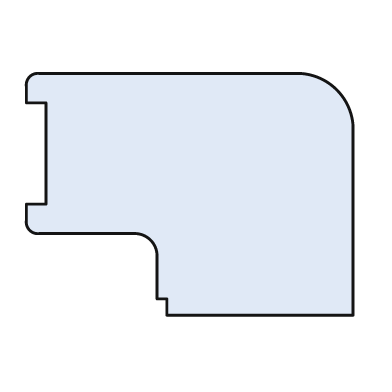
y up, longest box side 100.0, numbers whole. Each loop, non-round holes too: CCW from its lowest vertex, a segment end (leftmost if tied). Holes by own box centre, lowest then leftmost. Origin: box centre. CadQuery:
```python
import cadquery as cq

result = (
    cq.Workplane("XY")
    .moveTo(-7.0, -37.0)
    .lineTo(50.0, -37.0)
    .lineTo(50.0, 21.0)
    .threePointArc((45.0, 32.0), (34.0, 37.0))
    .lineTo(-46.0, 37.0)
    .threePointArc((-49.0, 36.0), (-50.0, 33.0))
    .lineTo(-50.0, 28.0)
    .lineTo(-44.0, 28.0)
    .lineTo(-44.0, -3.0)
    .lineTo(-50.0, -3.0)
    .lineTo(-50.0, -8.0)
    .threePointArc((-49.0, -11.0), (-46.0, -12.0))
    .lineTo(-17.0, -12.0)
    .threePointArc((-12.0, -14.0), (-10.0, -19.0))
    .lineTo(-10.0, -32.0)
    .lineTo(-7.0, -32.0)
    .close()
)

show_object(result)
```